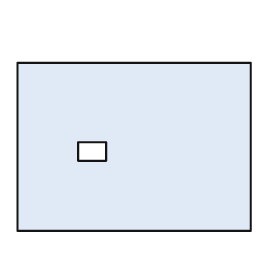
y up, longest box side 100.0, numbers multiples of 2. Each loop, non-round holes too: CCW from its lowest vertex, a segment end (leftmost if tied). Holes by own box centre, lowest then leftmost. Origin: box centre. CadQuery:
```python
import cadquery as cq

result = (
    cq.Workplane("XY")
    .moveTo(-50.0, -36.0)
    .lineTo(50.0, -36.0)
    .lineTo(50.0, 36.0)
    .lineTo(-50.0, 36.0)
    .close()
    .moveTo(-24.0, -6.0)
    .lineTo(-12.0, -6.0)
    .lineTo(-12.0, 2.0)
    .lineTo(-24.0, 2.0)
    .close()
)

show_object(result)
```